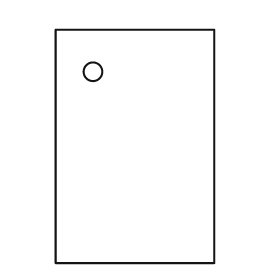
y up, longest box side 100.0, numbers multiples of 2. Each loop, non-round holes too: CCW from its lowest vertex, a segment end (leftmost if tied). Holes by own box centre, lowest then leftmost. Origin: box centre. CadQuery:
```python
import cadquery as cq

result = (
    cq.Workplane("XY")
    .moveTo(-34.0, -50.0)
    .lineTo(34.0, -50.0)
    .lineTo(34.0, 50.0)
    .lineTo(-34.0, 50.0)
    .close()
    .moveTo(-18.0, 32.0)
    .circle(4.0)
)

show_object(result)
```